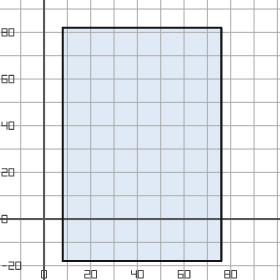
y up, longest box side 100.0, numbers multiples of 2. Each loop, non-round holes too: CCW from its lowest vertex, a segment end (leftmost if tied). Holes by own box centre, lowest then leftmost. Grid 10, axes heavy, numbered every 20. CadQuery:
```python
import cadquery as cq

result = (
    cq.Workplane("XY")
    .moveTo(8.0, -18.0)
    .lineTo(76.0, -18.0)
    .lineTo(76.0, 82.0)
    .lineTo(8.0, 82.0)
    .close()
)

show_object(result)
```